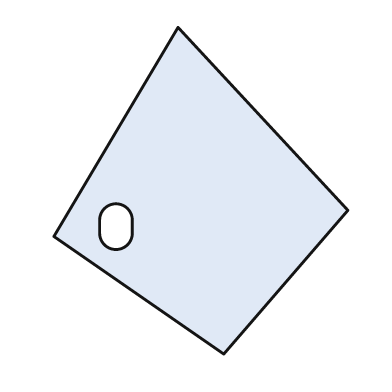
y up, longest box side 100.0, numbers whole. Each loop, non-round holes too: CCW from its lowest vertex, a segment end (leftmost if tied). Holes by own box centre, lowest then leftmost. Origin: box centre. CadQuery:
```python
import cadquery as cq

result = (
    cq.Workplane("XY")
    .moveTo(7.0, -50.0)
    .lineTo(45.0, -6.0)
    .lineTo(-7.0, 50.0)
    .lineTo(-45.0, -14.0)
    .close()
    .moveTo(-31.0, -13.0)
    .threePointArc((-26.0, -18.0), (-21.0, -13.0))
    .lineTo(-21.0, -9.0)
    .threePointArc((-26.0, -4.0), (-31.0, -9.0))
    .close()
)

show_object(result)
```